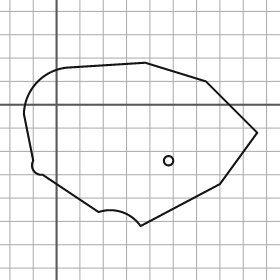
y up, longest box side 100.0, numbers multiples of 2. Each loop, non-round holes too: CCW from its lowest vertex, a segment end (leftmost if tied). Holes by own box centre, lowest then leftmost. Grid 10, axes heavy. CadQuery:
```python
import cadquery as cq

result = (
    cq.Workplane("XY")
    .moveTo(36.0, -52.0)
    .lineTo(70.0, -34.0)
    .lineTo(86.0, -12.0)
    .lineTo(64.0, 10.0)
    .lineTo(38.0, 18.0)
    .lineTo(6.0, 16.0)
    .threePointArc((-8.0, 10.0), (-14.0, -4.0))
    .lineTo(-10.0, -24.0)
    .threePointArc((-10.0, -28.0), (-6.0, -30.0))
    .lineTo(18.0, -46.0)
    .threePointArc((28.0, -46.0), (36.0, -52.0))
    .close()
    .moveTo(48.0, -24.0)
    .circle(2.0)
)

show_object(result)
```